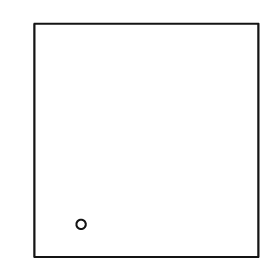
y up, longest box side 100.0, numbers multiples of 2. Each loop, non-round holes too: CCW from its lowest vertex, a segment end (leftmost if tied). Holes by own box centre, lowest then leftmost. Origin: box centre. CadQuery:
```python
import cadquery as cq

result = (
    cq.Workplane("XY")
    .moveTo(-48.0, -50.0)
    .lineTo(48.0, -50.0)
    .lineTo(48.0, 50.0)
    .lineTo(-48.0, 50.0)
    .close()
    .moveTo(-28.0, -36.0)
    .circle(2.0)
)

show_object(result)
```